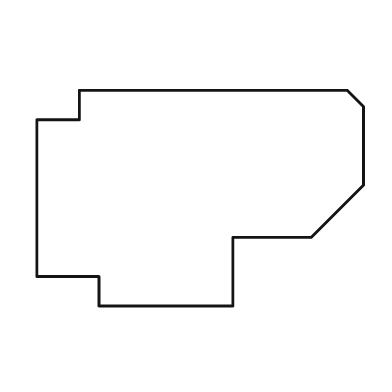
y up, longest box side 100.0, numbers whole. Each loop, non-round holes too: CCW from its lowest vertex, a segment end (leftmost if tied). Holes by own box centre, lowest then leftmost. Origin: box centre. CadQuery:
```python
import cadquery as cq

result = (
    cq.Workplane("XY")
    .moveTo(-31.0, -33.0)
    .lineTo(10.0, -33.0)
    .lineTo(10.0, -12.0)
    .lineTo(34.0, -12.0)
    .lineTo(50.0, 4.0)
    .lineTo(50.0, 28.0)
    .lineTo(45.0, 33.0)
    .lineTo(-37.0, 33.0)
    .lineTo(-37.0, 24.0)
    .lineTo(-50.0, 24.0)
    .lineTo(-50.0, -24.0)
    .lineTo(-31.0, -24.0)
    .close()
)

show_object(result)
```